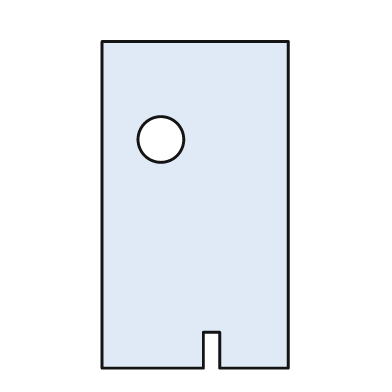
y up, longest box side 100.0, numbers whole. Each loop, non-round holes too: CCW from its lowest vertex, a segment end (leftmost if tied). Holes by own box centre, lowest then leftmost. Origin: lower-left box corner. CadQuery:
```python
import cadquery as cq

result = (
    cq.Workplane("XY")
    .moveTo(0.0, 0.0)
    .lineTo(31.0, 0.0)
    .lineTo(31.0, 11.0)
    .lineTo(36.0, 11.0)
    .lineTo(36.0, 0.0)
    .lineTo(57.0, 0.0)
    .lineTo(57.0, 100.0)
    .lineTo(0.0, 100.0)
    .close()
    .moveTo(18.0, 70.0)
    .circle(7.0)
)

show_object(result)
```